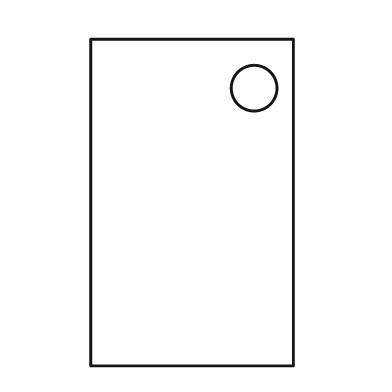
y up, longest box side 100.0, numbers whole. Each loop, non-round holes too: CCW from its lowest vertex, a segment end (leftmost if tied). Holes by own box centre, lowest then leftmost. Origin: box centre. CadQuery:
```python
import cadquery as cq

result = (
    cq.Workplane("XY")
    .moveTo(-31.0, -50.0)
    .lineTo(31.0, -50.0)
    .lineTo(31.0, 50.0)
    .lineTo(-31.0, 50.0)
    .close()
    .moveTo(19.0, 35.0)
    .circle(7.0)
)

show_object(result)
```